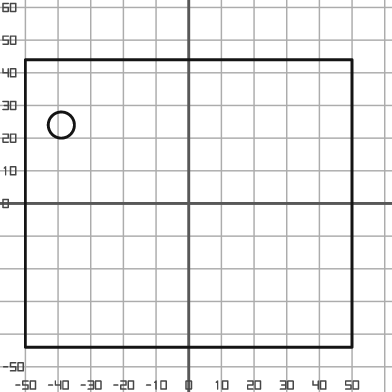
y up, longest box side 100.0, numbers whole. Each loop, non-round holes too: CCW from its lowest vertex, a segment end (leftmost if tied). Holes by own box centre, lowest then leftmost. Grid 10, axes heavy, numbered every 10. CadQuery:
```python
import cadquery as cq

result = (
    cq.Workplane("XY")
    .moveTo(-50.0, -44.0)
    .lineTo(50.0, -44.0)
    .lineTo(50.0, 44.0)
    .lineTo(-50.0, 44.0)
    .close()
    .moveTo(-39.0, 24.0)
    .circle(4.0)
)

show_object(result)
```